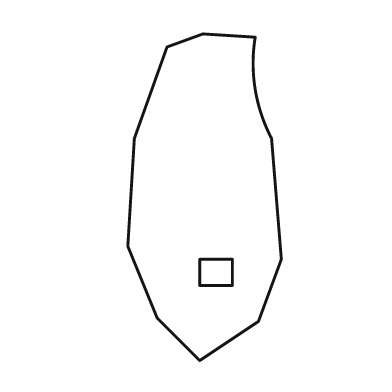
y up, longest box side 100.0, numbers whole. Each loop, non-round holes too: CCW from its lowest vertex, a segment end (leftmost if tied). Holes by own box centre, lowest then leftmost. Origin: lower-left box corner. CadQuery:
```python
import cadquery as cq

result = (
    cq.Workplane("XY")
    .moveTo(22.0, 0.0)
    .lineTo(40.0, 12.0)
    .lineTo(47.0, 31.0)
    .lineTo(44.0, 68.0)
    .threePointArc((39.0, 83.0), (39.0, 99.0))
    .lineTo(23.0, 100.0)
    .lineTo(12.0, 96.0)
    .lineTo(2.0, 68.0)
    .lineTo(0.0, 35.0)
    .lineTo(9.0, 13.0)
    .close()
    .moveTo(22.0, 23.0)
    .lineTo(32.0, 23.0)
    .lineTo(32.0, 31.0)
    .lineTo(22.0, 31.0)
    .close()
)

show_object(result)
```